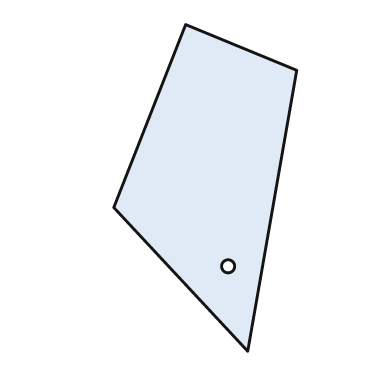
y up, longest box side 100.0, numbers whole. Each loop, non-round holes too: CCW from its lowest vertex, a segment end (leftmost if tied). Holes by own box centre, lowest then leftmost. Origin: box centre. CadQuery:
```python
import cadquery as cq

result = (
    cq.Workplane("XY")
    .moveTo(13.0, -50.0)
    .lineTo(28.0, 36.0)
    .lineTo(-6.0, 50.0)
    .lineTo(-28.0, -6.0)
    .close()
    .moveTo(7.0, -24.0)
    .circle(2.0)
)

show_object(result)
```